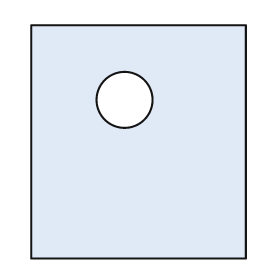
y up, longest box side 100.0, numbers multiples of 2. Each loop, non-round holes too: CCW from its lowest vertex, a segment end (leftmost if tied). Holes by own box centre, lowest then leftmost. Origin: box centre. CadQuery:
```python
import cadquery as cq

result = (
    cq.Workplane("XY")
    .moveTo(-46.0, -50.0)
    .lineTo(46.0, -50.0)
    .lineTo(46.0, 50.0)
    .lineTo(-46.0, 50.0)
    .close()
    .moveTo(-6.0, 18.0)
    .circle(12.0)
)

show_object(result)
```